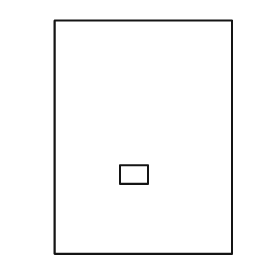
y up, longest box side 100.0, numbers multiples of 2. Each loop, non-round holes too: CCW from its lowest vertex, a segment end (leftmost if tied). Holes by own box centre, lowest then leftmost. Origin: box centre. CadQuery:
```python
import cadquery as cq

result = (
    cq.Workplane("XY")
    .moveTo(-38.0, -50.0)
    .lineTo(38.0, -50.0)
    .lineTo(38.0, 50.0)
    .lineTo(-38.0, 50.0)
    .close()
    .moveTo(-10.0, -20.0)
    .lineTo(2.0, -20.0)
    .lineTo(2.0, -12.0)
    .lineTo(-10.0, -12.0)
    .close()
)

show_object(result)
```